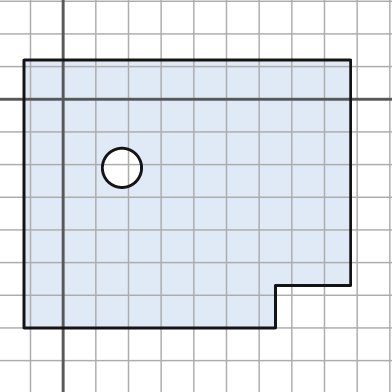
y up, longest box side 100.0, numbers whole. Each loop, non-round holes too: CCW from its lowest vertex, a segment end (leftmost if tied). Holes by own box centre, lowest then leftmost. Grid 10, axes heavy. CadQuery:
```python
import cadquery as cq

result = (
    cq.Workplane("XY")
    .moveTo(-12.0, -70.0)
    .lineTo(65.0, -70.0)
    .lineTo(65.0, -57.0)
    .lineTo(88.0, -57.0)
    .lineTo(88.0, 12.0)
    .lineTo(-12.0, 12.0)
    .close()
    .moveTo(18.0, -21.0)
    .circle(6.0)
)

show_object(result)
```